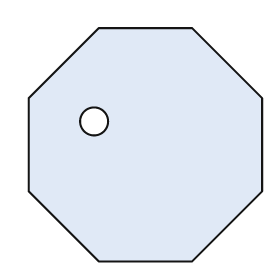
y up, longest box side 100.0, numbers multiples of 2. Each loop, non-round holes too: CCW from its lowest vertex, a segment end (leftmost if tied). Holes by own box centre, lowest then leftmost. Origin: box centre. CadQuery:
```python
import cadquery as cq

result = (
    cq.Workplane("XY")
    .moveTo(-20.0, -50.0)
    .lineTo(20.0, -50.0)
    .lineTo(50.0, -20.0)
    .lineTo(50.0, 20.0)
    .lineTo(20.0, 50.0)
    .lineTo(-20.0, 50.0)
    .lineTo(-50.0, 20.0)
    .lineTo(-50.0, -20.0)
    .close()
    .moveTo(-22.0, 10.0)
    .circle(6.0)
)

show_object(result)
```